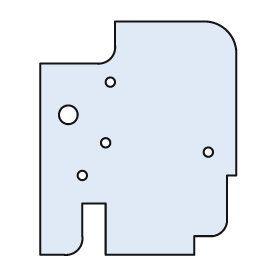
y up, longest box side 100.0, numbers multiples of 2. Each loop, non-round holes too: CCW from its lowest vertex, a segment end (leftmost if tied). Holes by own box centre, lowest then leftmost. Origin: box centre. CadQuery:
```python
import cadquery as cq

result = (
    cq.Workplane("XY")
    .moveTo(-42.0, -50.0)
    .lineTo(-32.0, -50.0)
    .threePointArc((-26.0, -48.0), (-24.0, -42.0))
    .lineTo(-24.0, -28.0)
    .lineTo(-14.0, -28.0)
    .lineTo(-14.0, -50.0)
    .lineTo(24.0, -50.0)
    .lineTo(24.0, -42.0)
    .lineTo(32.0, -42.0)
    .threePointArc((36.0, -40.0), (38.0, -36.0))
    .lineTo(38.0, -16.0)
    .lineTo(42.0, -16.0)
    .lineTo(42.0, 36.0)
    .threePointArc((38.0, 46.0), (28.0, 50.0))
    .lineTo(-10.0, 50.0)
    .lineTo(-10.0, 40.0)
    .threePointArc((-12.0, 34.0), (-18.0, 32.0))
    .lineTo(-42.0, 32.0)
    .close()
    .moveTo(-24.0, -16.0)
    .circle(2.0)
    .moveTo(30.0, -6.0)
    .circle(2.0)
    .moveTo(-14.0, -2.0)
    .circle(2.0)
    .moveTo(-30.0, 10.0)
    .circle(4.0)
    .moveTo(-12.0, 24.0)
    .circle(2.0)
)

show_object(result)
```